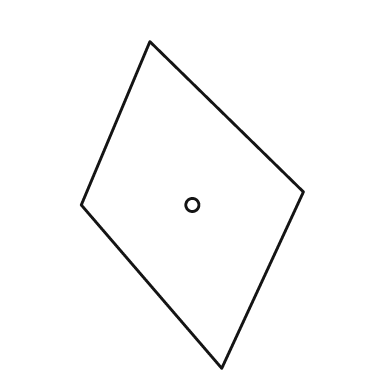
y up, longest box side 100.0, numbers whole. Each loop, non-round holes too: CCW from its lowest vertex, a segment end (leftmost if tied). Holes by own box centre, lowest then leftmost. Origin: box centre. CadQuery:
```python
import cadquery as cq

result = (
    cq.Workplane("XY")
    .moveTo(9.0, -50.0)
    .lineTo(34.0, 4.0)
    .lineTo(-13.0, 50.0)
    .lineTo(-34.0, 0.0)
    .close()
    .moveTo(0.0, 0.0)
    .circle(2.0)
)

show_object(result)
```